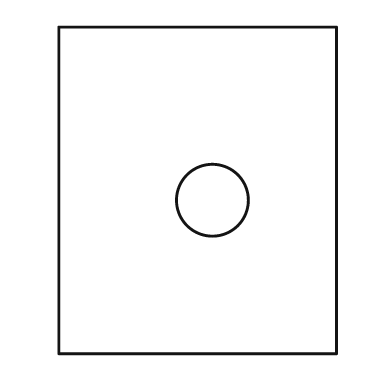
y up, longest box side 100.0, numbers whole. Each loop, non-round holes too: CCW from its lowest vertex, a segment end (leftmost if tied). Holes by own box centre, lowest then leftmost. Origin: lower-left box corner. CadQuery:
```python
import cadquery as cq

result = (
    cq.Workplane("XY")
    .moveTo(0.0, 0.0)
    .lineTo(85.0, 0.0)
    .lineTo(85.0, 100.0)
    .lineTo(0.0, 100.0)
    .close()
    .moveTo(47.0, 47.0)
    .circle(11.0)
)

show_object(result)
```